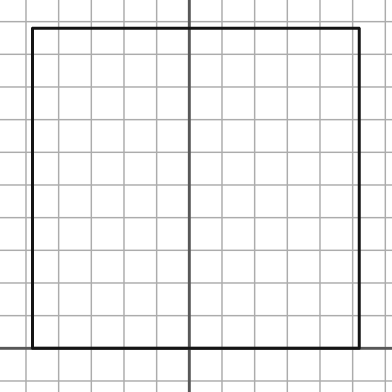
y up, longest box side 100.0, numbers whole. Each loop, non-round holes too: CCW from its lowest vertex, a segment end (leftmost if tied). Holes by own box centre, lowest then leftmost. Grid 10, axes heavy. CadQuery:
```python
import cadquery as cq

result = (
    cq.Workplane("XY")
    .moveTo(-48.0, 0.0)
    .lineTo(52.0, 0.0)
    .lineTo(52.0, 98.0)
    .lineTo(-48.0, 98.0)
    .close()
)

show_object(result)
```